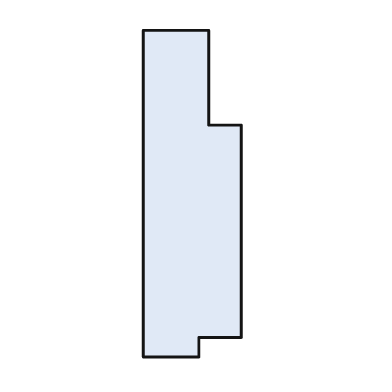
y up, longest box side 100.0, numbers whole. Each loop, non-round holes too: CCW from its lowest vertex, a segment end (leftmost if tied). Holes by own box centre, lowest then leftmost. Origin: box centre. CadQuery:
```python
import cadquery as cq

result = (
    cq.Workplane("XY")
    .moveTo(-15.0, -50.0)
    .lineTo(2.0, -50.0)
    .lineTo(2.0, -44.0)
    .lineTo(15.0, -44.0)
    .lineTo(15.0, 21.0)
    .lineTo(5.0, 21.0)
    .lineTo(5.0, 50.0)
    .lineTo(-15.0, 50.0)
    .close()
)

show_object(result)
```